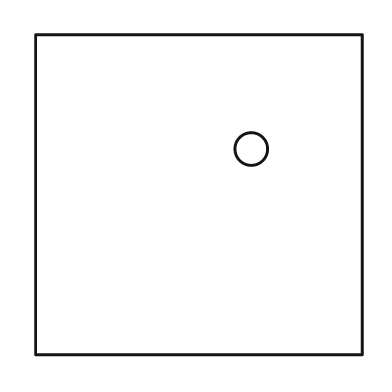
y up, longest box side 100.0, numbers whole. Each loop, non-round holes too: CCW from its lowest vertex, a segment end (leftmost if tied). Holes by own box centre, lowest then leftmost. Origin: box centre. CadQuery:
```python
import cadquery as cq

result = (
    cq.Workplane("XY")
    .moveTo(-50.0, -49.0)
    .lineTo(50.0, -49.0)
    .lineTo(50.0, 49.0)
    .lineTo(-50.0, 49.0)
    .close()
    .moveTo(16.0, 14.0)
    .circle(5.0)
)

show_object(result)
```